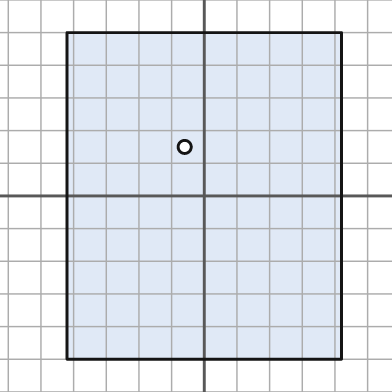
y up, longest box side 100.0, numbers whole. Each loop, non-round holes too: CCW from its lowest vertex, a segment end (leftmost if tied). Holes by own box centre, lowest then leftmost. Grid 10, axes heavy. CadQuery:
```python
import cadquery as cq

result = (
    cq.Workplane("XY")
    .moveTo(-42.0, -50.0)
    .lineTo(42.0, -50.0)
    .lineTo(42.0, 50.0)
    .lineTo(-42.0, 50.0)
    .close()
    .moveTo(-6.0, 15.0)
    .circle(2.0)
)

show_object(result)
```